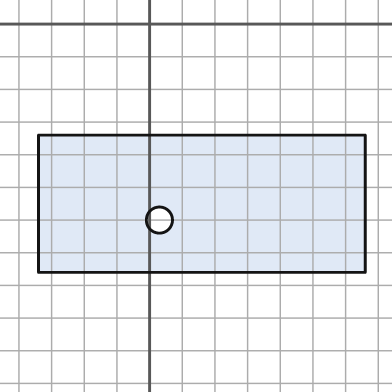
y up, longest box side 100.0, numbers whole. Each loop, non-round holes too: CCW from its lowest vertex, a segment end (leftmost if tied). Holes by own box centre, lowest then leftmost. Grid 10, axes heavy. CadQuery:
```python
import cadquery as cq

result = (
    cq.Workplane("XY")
    .moveTo(-34.0, -76.0)
    .lineTo(66.0, -76.0)
    .lineTo(66.0, -34.0)
    .lineTo(-34.0, -34.0)
    .close()
    .moveTo(3.0, -60.0)
    .circle(4.0)
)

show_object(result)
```